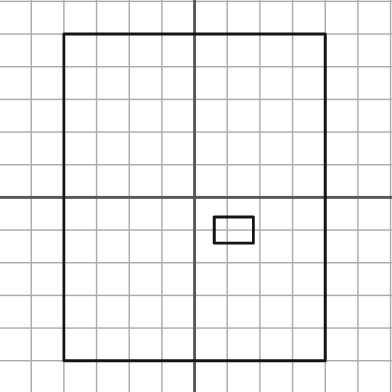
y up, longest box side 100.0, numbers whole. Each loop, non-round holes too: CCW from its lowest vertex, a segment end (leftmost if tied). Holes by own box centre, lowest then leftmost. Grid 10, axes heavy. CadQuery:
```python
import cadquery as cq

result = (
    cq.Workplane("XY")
    .moveTo(-40.0, -50.0)
    .lineTo(40.0, -50.0)
    .lineTo(40.0, 50.0)
    .lineTo(-40.0, 50.0)
    .close()
    .moveTo(6.0, -14.0)
    .lineTo(18.0, -14.0)
    .lineTo(18.0, -6.0)
    .lineTo(6.0, -6.0)
    .close()
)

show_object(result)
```